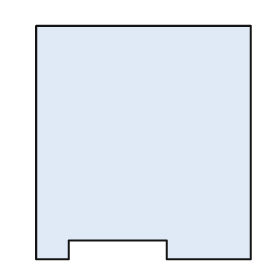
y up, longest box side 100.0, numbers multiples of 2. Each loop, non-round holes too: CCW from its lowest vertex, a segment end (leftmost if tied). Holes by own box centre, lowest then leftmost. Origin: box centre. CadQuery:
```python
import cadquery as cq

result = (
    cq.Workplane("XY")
    .moveTo(-46.0, -50.0)
    .lineTo(-32.0, -50.0)
    .lineTo(-32.0, -42.0)
    .lineTo(10.0, -42.0)
    .lineTo(10.0, -50.0)
    .lineTo(46.0, -50.0)
    .lineTo(46.0, 50.0)
    .lineTo(-46.0, 50.0)
    .close()
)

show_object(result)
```